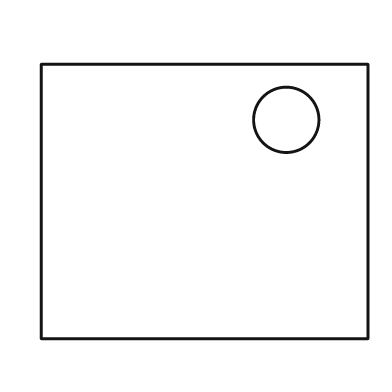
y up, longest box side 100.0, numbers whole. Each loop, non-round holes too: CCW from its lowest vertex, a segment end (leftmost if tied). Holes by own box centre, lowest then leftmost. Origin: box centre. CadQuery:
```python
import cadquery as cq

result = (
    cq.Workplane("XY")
    .moveTo(-50.0, -42.0)
    .lineTo(50.0, -42.0)
    .lineTo(50.0, 42.0)
    .lineTo(-50.0, 42.0)
    .close()
    .moveTo(25.0, 25.0)
    .circle(10.0)
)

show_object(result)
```